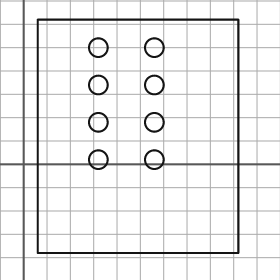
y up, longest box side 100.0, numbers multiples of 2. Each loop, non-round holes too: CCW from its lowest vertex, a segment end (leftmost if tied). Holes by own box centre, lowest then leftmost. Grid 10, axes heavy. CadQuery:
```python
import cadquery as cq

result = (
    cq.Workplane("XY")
    .moveTo(6.0, -38.0)
    .lineTo(92.0, -38.0)
    .lineTo(92.0, 62.0)
    .lineTo(6.0, 62.0)
    .close()
    .moveTo(32.0, 2.0)
    .circle(4.0)
    .moveTo(56.0, 2.0)
    .circle(4.0)
    .moveTo(32.0, 18.0)
    .circle(4.0)
    .moveTo(56.0, 18.0)
    .circle(4.0)
    .moveTo(32.0, 34.0)
    .circle(4.0)
    .moveTo(56.0, 34.0)
    .circle(4.0)
    .moveTo(32.0, 50.0)
    .circle(4.0)
    .moveTo(56.0, 50.0)
    .circle(4.0)
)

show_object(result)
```